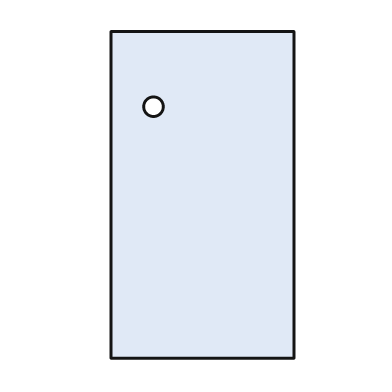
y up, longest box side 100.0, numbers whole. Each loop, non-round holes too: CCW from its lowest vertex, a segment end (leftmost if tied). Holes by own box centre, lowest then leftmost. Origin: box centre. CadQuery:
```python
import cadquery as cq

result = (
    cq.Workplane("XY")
    .moveTo(-28.0, -50.0)
    .lineTo(28.0, -50.0)
    .lineTo(28.0, 50.0)
    .lineTo(-28.0, 50.0)
    .close()
    .moveTo(-15.0, 27.0)
    .circle(3.0)
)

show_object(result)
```